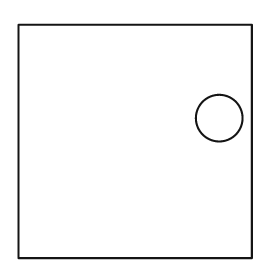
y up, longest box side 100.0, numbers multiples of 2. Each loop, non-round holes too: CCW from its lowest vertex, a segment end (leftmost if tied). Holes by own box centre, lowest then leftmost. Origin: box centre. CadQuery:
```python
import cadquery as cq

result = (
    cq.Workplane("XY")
    .moveTo(-50.0, -50.0)
    .lineTo(50.0, -50.0)
    .lineTo(50.0, 50.0)
    .lineTo(-50.0, 50.0)
    .close()
    .moveTo(36.0, 10.0)
    .circle(10.0)
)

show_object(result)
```